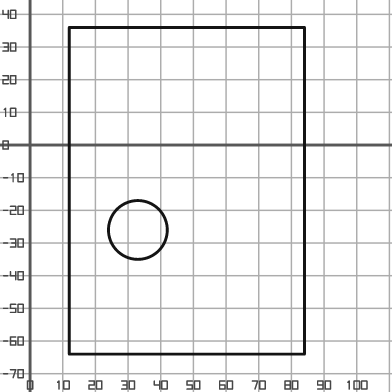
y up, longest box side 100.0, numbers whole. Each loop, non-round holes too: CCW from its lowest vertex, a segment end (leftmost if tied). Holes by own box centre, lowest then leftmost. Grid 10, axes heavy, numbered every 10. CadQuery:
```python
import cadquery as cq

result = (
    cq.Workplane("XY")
    .moveTo(12.0, -64.0)
    .lineTo(84.0, -64.0)
    .lineTo(84.0, 36.0)
    .lineTo(12.0, 36.0)
    .close()
    .moveTo(33.0, -26.0)
    .circle(9.0)
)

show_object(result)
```